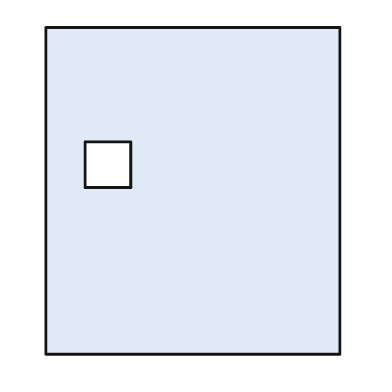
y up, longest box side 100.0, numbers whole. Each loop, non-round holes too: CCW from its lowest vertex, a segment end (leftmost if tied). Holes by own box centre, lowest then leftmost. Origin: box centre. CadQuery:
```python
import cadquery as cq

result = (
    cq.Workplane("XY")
    .moveTo(-45.0, -50.0)
    .lineTo(45.0, -50.0)
    .lineTo(45.0, 50.0)
    .lineTo(-45.0, 50.0)
    .close()
    .moveTo(-33.0, 1.0)
    .lineTo(-19.0, 1.0)
    .lineTo(-19.0, 15.0)
    .lineTo(-33.0, 15.0)
    .close()
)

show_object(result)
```